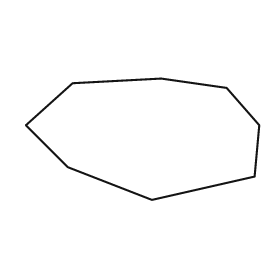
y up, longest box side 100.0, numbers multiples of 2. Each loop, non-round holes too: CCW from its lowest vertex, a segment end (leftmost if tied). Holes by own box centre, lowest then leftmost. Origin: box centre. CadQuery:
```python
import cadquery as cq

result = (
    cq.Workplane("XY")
    .moveTo(4.0, -26.0)
    .lineTo(48.0, -16.0)
    .lineTo(50.0, 6.0)
    .lineTo(36.0, 22.0)
    .lineTo(8.0, 26.0)
    .lineTo(-30.0, 24.0)
    .lineTo(-50.0, 6.0)
    .lineTo(-32.0, -12.0)
    .close()
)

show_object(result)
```